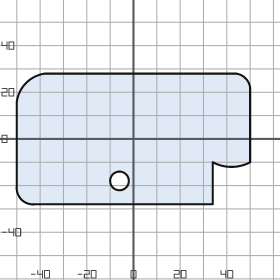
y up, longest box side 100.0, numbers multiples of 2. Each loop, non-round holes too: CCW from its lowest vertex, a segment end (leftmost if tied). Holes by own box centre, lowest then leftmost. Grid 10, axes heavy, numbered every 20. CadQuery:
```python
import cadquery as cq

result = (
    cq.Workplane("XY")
    .moveTo(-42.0, -28.0)
    .lineTo(34.0, -28.0)
    .lineTo(34.0, -10.0)
    .threePointArc((42.0, -12.0), (50.0, -10.0))
    .lineTo(50.0, 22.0)
    .threePointArc((48.0, 26.0), (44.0, 28.0))
    .lineTo(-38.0, 28.0)
    .threePointArc((-46.0, 24.0), (-50.0, 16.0))
    .lineTo(-50.0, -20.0)
    .threePointArc((-48.0, -26.0), (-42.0, -28.0))
    .close()
    .moveTo(-6.0, -18.0)
    .circle(4.0)
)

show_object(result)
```